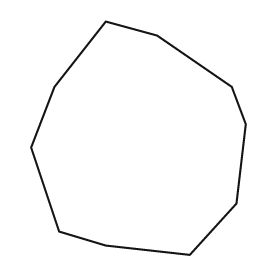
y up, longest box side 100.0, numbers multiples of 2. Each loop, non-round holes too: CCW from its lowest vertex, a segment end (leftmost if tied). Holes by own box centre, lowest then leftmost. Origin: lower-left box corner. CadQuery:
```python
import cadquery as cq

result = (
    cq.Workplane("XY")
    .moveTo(68.0, 0.0)
    .lineTo(88.0, 22.0)
    .lineTo(92.0, 56.0)
    .lineTo(86.0, 72.0)
    .lineTo(54.0, 94.0)
    .lineTo(32.0, 100.0)
    .lineTo(10.0, 72.0)
    .lineTo(0.0, 46.0)
    .lineTo(12.0, 10.0)
    .lineTo(32.0, 4.0)
    .close()
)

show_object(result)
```